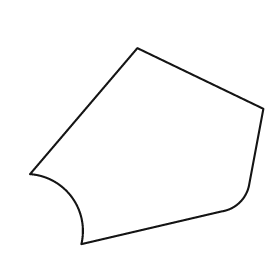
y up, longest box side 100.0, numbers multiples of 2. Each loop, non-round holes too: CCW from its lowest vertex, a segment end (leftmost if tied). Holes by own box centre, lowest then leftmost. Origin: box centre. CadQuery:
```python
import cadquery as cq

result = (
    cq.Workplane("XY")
    .moveTo(-28.0, -42.0)
    .lineTo(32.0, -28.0)
    .threePointArc((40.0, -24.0), (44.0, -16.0))
    .lineTo(50.0, 16.0)
    .lineTo(-4.0, 42.0)
    .lineTo(-50.0, -12.0)
    .threePointArc((-32.0, -22.0), (-28.0, -42.0))
    .close()
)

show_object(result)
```